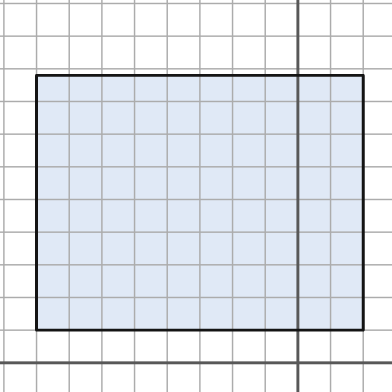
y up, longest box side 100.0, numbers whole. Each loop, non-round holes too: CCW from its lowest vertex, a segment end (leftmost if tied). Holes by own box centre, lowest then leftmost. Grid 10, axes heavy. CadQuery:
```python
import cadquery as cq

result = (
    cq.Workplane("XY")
    .moveTo(-80.0, 10.0)
    .lineTo(20.0, 10.0)
    .lineTo(20.0, 88.0)
    .lineTo(-80.0, 88.0)
    .close()
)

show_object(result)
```